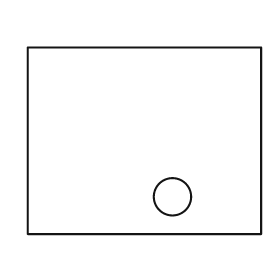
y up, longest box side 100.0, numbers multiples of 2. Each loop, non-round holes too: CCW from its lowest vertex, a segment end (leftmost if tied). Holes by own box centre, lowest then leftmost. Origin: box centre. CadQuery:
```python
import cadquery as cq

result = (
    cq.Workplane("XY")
    .moveTo(-50.0, -40.0)
    .lineTo(50.0, -40.0)
    .lineTo(50.0, 40.0)
    .lineTo(-50.0, 40.0)
    .close()
    .moveTo(12.0, -24.0)
    .circle(8.0)
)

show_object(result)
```